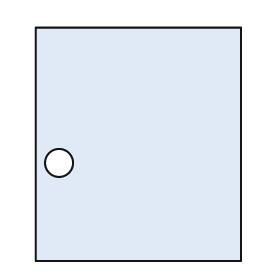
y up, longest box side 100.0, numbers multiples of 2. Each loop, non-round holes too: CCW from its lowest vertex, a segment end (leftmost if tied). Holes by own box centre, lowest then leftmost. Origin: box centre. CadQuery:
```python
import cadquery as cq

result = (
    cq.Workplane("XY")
    .moveTo(-44.0, -50.0)
    .lineTo(44.0, -50.0)
    .lineTo(44.0, 50.0)
    .lineTo(-44.0, 50.0)
    .close()
    .moveTo(-34.0, -8.0)
    .circle(6.0)
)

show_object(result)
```